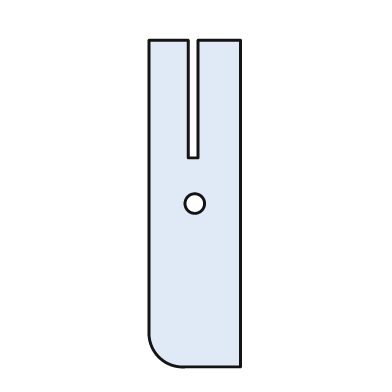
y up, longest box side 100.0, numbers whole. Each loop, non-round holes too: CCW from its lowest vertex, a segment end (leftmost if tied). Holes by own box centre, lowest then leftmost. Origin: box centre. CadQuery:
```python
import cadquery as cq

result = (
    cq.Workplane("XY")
    .moveTo(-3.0, -50.0)
    .lineTo(14.0, -50.0)
    .lineTo(14.0, 50.0)
    .lineTo(1.0, 50.0)
    .lineTo(1.0, 14.0)
    .lineTo(-2.0, 14.0)
    .lineTo(-2.0, 50.0)
    .lineTo(-14.0, 50.0)
    .lineTo(-14.0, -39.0)
    .threePointArc((-11.0, -47.0), (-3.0, -50.0))
    .close()
    .moveTo(0.0, 0.0)
    .circle(3.0)
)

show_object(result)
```